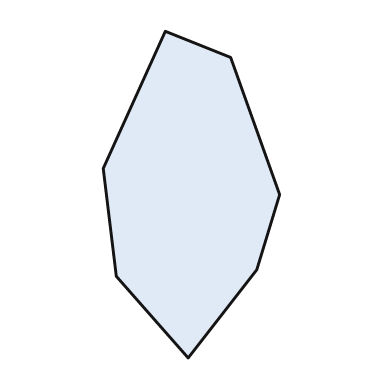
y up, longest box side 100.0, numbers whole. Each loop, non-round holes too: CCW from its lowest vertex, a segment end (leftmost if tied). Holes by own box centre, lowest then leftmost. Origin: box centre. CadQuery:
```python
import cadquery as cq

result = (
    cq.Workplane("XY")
    .moveTo(-1.0, -50.0)
    .lineTo(20.0, -23.0)
    .lineTo(27.0, 0.0)
    .lineTo(12.0, 42.0)
    .lineTo(-8.0, 50.0)
    .lineTo(-27.0, 8.0)
    .lineTo(-23.0, -25.0)
    .close()
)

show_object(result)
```